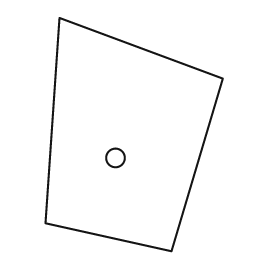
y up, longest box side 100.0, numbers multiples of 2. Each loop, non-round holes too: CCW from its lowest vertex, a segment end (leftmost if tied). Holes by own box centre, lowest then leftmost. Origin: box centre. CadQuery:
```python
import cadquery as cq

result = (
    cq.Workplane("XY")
    .moveTo(16.0, -50.0)
    .lineTo(38.0, 24.0)
    .lineTo(-32.0, 50.0)
    .lineTo(-38.0, -38.0)
    .close()
    .moveTo(-8.0, -10.0)
    .circle(4.0)
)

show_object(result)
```